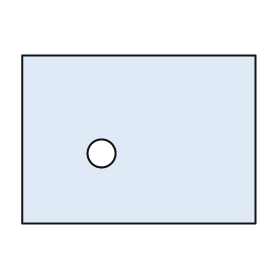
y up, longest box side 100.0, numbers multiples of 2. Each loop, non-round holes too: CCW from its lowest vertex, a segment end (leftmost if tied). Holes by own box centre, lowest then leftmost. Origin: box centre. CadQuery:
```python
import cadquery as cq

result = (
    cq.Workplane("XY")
    .moveTo(-50.0, -36.0)
    .lineTo(50.0, -36.0)
    .lineTo(50.0, 36.0)
    .lineTo(-50.0, 36.0)
    .close()
    .moveTo(-16.0, -6.0)
    .circle(6.0)
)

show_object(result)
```